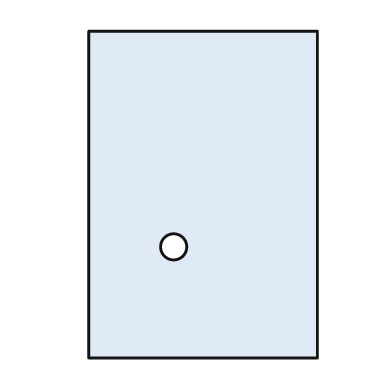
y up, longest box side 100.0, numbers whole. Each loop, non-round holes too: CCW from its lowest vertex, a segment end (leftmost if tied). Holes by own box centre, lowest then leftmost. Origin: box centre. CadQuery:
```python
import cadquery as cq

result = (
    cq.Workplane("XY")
    .moveTo(-35.0, -50.0)
    .lineTo(35.0, -50.0)
    .lineTo(35.0, 50.0)
    .lineTo(-35.0, 50.0)
    .close()
    .moveTo(-9.0, -16.0)
    .circle(4.0)
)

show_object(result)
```